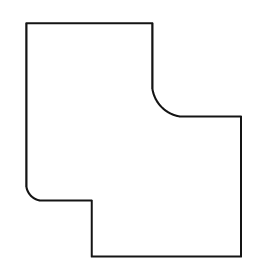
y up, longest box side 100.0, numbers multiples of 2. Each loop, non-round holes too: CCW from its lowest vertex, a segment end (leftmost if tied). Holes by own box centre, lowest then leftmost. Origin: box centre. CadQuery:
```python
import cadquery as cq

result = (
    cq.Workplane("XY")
    .moveTo(-18.0, -50.0)
    .lineTo(46.0, -50.0)
    .lineTo(46.0, 10.0)
    .lineTo(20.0, 10.0)
    .threePointArc((12.0, 14.0), (8.0, 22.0))
    .lineTo(8.0, 50.0)
    .lineTo(-46.0, 50.0)
    .lineTo(-46.0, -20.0)
    .threePointArc((-44.0, -24.0), (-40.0, -26.0))
    .lineTo(-18.0, -26.0)
    .close()
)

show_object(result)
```